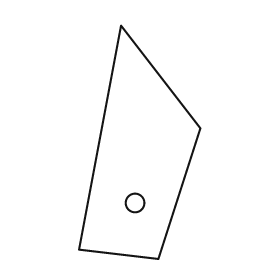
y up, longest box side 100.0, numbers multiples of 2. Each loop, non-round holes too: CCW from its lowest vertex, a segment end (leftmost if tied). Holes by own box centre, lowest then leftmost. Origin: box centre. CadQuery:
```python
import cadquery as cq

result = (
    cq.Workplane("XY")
    .moveTo(8.0, -50.0)
    .lineTo(26.0, 6.0)
    .lineTo(-8.0, 50.0)
    .lineTo(-26.0, -46.0)
    .close()
    .moveTo(-2.0, -26.0)
    .circle(4.0)
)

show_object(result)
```